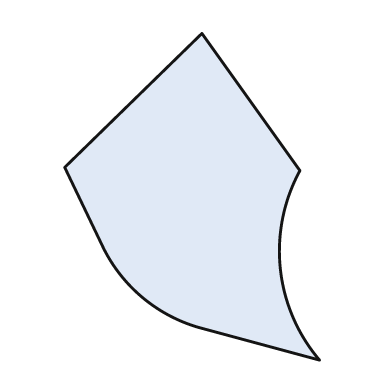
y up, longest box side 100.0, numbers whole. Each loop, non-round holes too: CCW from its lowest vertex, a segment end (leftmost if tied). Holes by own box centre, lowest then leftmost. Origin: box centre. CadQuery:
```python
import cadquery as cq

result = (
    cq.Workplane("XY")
    .moveTo(39.0, -50.0)
    .threePointArc((27.0, -22.0), (33.0, 8.0))
    .lineTo(3.0, 50.0)
    .lineTo(-39.0, 9.0)
    .lineTo(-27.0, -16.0)
    .threePointArc((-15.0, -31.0), (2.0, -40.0))
    .close()
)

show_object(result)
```